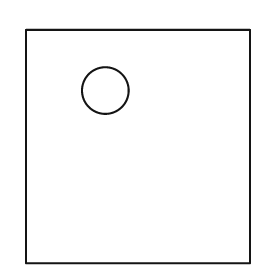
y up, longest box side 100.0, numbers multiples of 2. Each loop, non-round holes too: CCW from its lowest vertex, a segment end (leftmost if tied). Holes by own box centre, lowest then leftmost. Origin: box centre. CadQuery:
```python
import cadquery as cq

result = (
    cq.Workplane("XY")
    .moveTo(-48.0, -50.0)
    .lineTo(48.0, -50.0)
    .lineTo(48.0, 50.0)
    .lineTo(-48.0, 50.0)
    .close()
    .moveTo(-14.0, 24.0)
    .circle(10.0)
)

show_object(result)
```